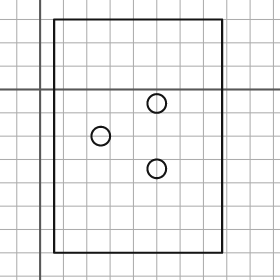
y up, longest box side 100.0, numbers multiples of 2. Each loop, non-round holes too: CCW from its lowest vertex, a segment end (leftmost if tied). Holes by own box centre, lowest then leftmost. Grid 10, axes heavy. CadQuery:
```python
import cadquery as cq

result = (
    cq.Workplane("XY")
    .moveTo(6.0, -70.0)
    .lineTo(78.0, -70.0)
    .lineTo(78.0, 30.0)
    .lineTo(6.0, 30.0)
    .close()
    .moveTo(50.0, -34.0)
    .circle(4.0)
    .moveTo(26.0, -20.0)
    .circle(4.0)
    .moveTo(50.0, -6.0)
    .circle(4.0)
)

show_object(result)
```